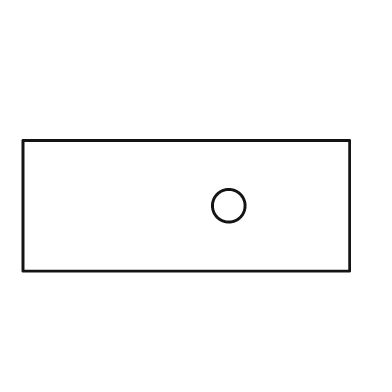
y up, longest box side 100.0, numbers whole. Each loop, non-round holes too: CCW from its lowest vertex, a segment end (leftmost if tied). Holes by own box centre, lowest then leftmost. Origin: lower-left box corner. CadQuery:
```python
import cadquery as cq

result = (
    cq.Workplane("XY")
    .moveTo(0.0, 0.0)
    .lineTo(100.0, 0.0)
    .lineTo(100.0, 40.0)
    .lineTo(0.0, 40.0)
    .close()
    .moveTo(63.0, 20.0)
    .circle(5.0)
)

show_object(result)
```